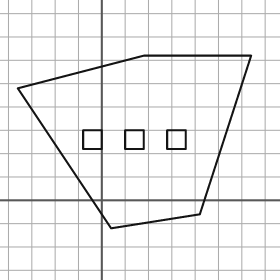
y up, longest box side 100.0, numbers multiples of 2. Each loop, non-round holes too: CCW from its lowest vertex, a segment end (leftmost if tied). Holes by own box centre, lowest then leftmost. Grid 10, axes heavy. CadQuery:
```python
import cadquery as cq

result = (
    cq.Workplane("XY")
    .moveTo(4.0, -12.0)
    .lineTo(42.0, -6.0)
    .lineTo(64.0, 62.0)
    .lineTo(18.0, 62.0)
    .lineTo(-36.0, 48.0)
    .close()
    .moveTo(-8.0, 22.0)
    .lineTo(0.0, 22.0)
    .lineTo(0.0, 30.0)
    .lineTo(-8.0, 30.0)
    .close()
    .moveTo(10.0, 22.0)
    .lineTo(18.0, 22.0)
    .lineTo(18.0, 30.0)
    .lineTo(10.0, 30.0)
    .close()
    .moveTo(28.0, 22.0)
    .lineTo(36.0, 22.0)
    .lineTo(36.0, 30.0)
    .lineTo(28.0, 30.0)
    .close()
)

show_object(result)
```